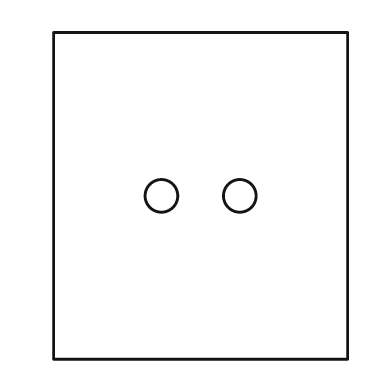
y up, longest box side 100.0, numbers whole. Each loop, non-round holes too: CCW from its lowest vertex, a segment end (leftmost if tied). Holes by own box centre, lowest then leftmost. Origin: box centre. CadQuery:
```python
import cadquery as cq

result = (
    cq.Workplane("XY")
    .moveTo(-45.0, -50.0)
    .lineTo(45.0, -50.0)
    .lineTo(45.0, 50.0)
    .lineTo(-45.0, 50.0)
    .close()
    .moveTo(-12.0, 0.0)
    .circle(5.0)
    .moveTo(12.0, 0.0)
    .circle(5.0)
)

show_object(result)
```